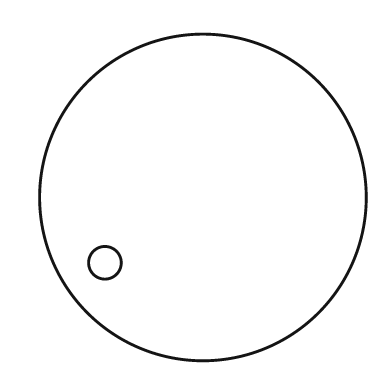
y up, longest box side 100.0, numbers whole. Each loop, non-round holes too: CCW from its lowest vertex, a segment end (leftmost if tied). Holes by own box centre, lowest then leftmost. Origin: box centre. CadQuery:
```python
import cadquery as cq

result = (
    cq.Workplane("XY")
    .moveTo(0.0, 0.0)
    .circle(50.0)
    .moveTo(-30.0, -20.0)
    .circle(5.0)
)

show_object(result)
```